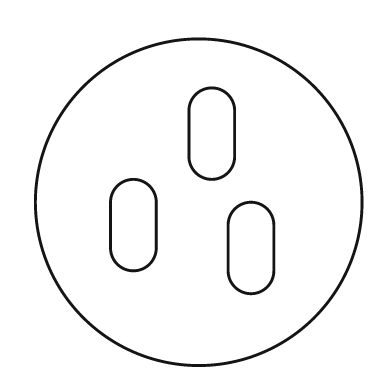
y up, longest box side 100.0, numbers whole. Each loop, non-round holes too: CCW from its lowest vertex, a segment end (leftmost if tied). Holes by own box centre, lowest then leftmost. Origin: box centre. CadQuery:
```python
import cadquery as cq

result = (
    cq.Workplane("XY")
    .moveTo(0.0, 0.0)
    .circle(50.0)
    .moveTo(9.0, -21.0)
    .threePointArc((16.0, -28.0), (23.0, -21.0))
    .lineTo(23.0, -7.0)
    .threePointArc((16.0, 0.0), (9.0, -7.0))
    .close()
    .moveTo(-27.0, -14.0)
    .threePointArc((-20.0, -21.0), (-13.0, -14.0))
    .lineTo(-13.0, 0.0)
    .threePointArc((-20.0, 7.0), (-27.0, 0.0))
    .close()
    .moveTo(-3.0, 14.0)
    .threePointArc((4.0, 7.0), (11.0, 14.0))
    .lineTo(11.0, 28.0)
    .threePointArc((4.0, 35.0), (-3.0, 28.0))
    .close()
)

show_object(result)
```